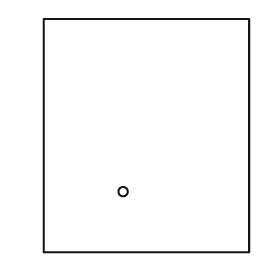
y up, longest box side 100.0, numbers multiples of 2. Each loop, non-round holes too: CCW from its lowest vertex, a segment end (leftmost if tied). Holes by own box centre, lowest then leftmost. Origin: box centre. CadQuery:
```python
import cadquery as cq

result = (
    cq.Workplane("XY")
    .moveTo(-44.0, -50.0)
    .lineTo(44.0, -50.0)
    .lineTo(44.0, 50.0)
    .lineTo(-44.0, 50.0)
    .close()
    .moveTo(-10.0, -24.0)
    .circle(2.0)
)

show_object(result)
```